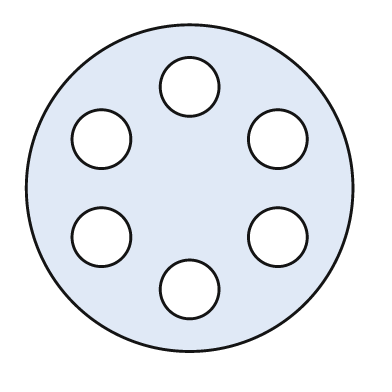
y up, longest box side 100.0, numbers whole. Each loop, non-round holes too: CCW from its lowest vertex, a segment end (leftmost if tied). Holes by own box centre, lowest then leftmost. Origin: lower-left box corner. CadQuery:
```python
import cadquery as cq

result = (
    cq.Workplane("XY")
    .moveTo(50.0, 50.0)
    .circle(50.0)
    .moveTo(50.0, 19.0)
    .circle(9.0)
    .moveTo(23.0, 35.0)
    .circle(9.0)
    .moveTo(77.0, 35.0)
    .circle(9.0)
    .moveTo(23.0, 65.0)
    .circle(9.0)
    .moveTo(77.0, 65.0)
    .circle(9.0)
    .moveTo(50.0, 81.0)
    .circle(9.0)
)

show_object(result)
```